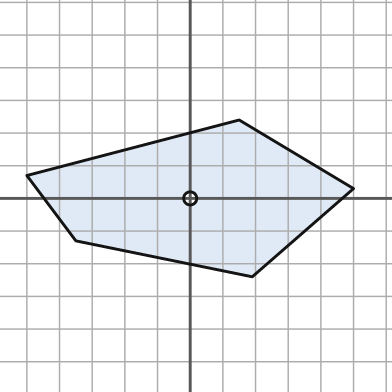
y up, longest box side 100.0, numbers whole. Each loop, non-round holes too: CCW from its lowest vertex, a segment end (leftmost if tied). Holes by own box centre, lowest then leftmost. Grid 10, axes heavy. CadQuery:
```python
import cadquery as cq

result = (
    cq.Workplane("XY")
    .moveTo(19.0, -24.0)
    .lineTo(50.0, 3.0)
    .lineTo(15.0, 24.0)
    .lineTo(-50.0, 7.0)
    .lineTo(-35.0, -13.0)
    .close()
    .moveTo(0.0, 0.0)
    .circle(2.0)
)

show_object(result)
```